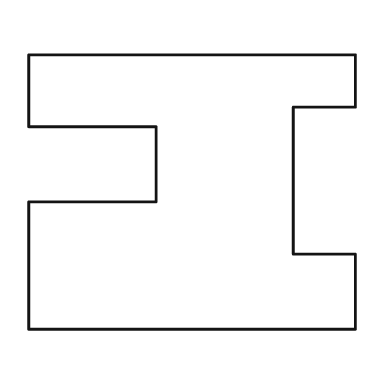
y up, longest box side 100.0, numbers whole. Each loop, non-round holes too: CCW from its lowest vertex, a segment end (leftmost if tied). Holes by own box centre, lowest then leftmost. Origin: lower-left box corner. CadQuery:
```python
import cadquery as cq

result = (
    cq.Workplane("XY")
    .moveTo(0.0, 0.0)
    .lineTo(100.0, 0.0)
    .lineTo(100.0, 23.0)
    .lineTo(81.0, 23.0)
    .lineTo(81.0, 68.0)
    .lineTo(100.0, 68.0)
    .lineTo(100.0, 84.0)
    .lineTo(0.0, 84.0)
    .lineTo(0.0, 62.0)
    .lineTo(39.0, 62.0)
    .lineTo(39.0, 39.0)
    .lineTo(0.0, 39.0)
    .close()
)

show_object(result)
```